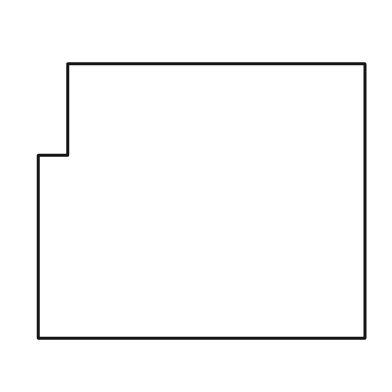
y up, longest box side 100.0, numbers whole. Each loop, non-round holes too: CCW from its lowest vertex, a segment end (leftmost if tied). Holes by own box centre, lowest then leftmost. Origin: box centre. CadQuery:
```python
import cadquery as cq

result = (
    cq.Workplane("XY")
    .moveTo(-50.0, -42.0)
    .lineTo(50.0, -42.0)
    .lineTo(50.0, 42.0)
    .lineTo(-41.0, 42.0)
    .lineTo(-41.0, 14.0)
    .lineTo(-50.0, 14.0)
    .close()
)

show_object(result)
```